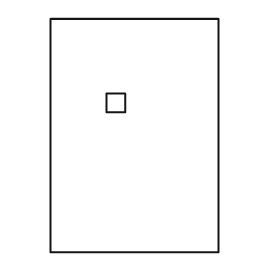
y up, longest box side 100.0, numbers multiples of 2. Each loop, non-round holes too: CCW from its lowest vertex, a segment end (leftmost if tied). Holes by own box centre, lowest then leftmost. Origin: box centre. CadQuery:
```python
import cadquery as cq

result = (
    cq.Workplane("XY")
    .moveTo(-36.0, -50.0)
    .lineTo(36.0, -50.0)
    .lineTo(36.0, 50.0)
    .lineTo(-36.0, 50.0)
    .close()
    .moveTo(-12.0, 10.0)
    .lineTo(-4.0, 10.0)
    .lineTo(-4.0, 18.0)
    .lineTo(-12.0, 18.0)
    .close()
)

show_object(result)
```